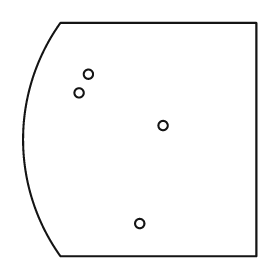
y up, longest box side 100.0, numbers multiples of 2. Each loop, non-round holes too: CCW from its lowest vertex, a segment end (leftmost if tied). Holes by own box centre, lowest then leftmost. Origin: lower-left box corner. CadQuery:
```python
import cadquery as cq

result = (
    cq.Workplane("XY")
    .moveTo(16.0, 0.0)
    .lineTo(100.0, 0.0)
    .lineTo(100.0, 100.0)
    .lineTo(16.0, 100.0)
    .threePointArc((0.0, 50.0), (16.0, 0.0))
    .close()
    .moveTo(50.0, 14.0)
    .circle(2.0)
    .moveTo(60.0, 56.0)
    .circle(2.0)
    .moveTo(24.0, 70.0)
    .circle(2.0)
    .moveTo(28.0, 78.0)
    .circle(2.0)
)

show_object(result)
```